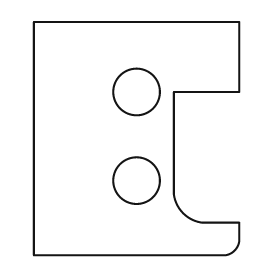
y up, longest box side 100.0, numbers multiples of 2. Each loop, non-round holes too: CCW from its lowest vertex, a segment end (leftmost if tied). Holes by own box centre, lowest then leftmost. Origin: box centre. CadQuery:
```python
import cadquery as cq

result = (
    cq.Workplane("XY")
    .moveTo(-44.0, -50.0)
    .lineTo(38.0, -50.0)
    .threePointArc((42.0, -48.0), (44.0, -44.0))
    .lineTo(44.0, -36.0)
    .lineTo(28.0, -36.0)
    .threePointArc((20.0, -32.0), (16.0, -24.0))
    .lineTo(16.0, 20.0)
    .lineTo(44.0, 20.0)
    .lineTo(44.0, 50.0)
    .lineTo(-44.0, 50.0)
    .close()
    .moveTo(0.0, -18.0)
    .circle(10.0)
    .moveTo(0.0, 20.0)
    .circle(10.0)
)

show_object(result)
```